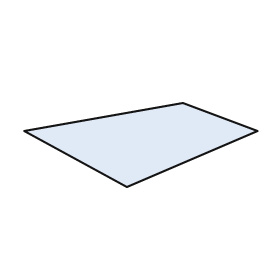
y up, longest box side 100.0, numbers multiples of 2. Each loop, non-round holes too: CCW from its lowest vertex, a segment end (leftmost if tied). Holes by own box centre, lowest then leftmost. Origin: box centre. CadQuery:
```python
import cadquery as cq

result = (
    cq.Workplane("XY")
    .moveTo(-6.0, -18.0)
    .lineTo(50.0, 6.0)
    .lineTo(18.0, 18.0)
    .lineTo(-50.0, 6.0)
    .close()
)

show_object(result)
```